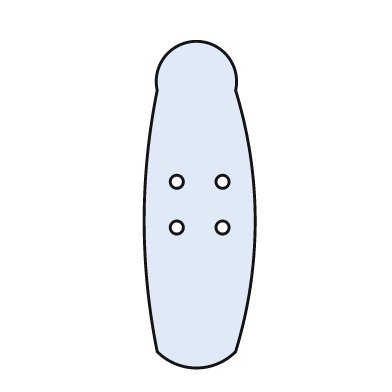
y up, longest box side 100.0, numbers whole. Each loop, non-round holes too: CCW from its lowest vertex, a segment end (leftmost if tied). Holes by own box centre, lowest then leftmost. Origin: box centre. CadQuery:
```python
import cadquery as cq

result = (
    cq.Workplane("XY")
    .moveTo(-13.0, -45.0)
    .threePointArc((-1.0, -50.0), (11.0, -45.0))
    .threePointArc((17.0, -5.0), (11.0, 35.0))
    .threePointArc((-1.0, 50.0), (-13.0, 35.0))
    .threePointArc((-17.0, -5.0), (-13.0, -45.0))
    .close()
    .moveTo(-7.0, -7.0)
    .circle(2.0)
    .moveTo(7.0, -7.0)
    .circle(2.0)
    .moveTo(-7.0, 7.0)
    .circle(2.0)
    .moveTo(7.0, 7.0)
    .circle(2.0)
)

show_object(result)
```